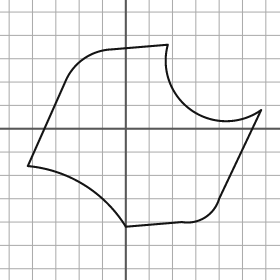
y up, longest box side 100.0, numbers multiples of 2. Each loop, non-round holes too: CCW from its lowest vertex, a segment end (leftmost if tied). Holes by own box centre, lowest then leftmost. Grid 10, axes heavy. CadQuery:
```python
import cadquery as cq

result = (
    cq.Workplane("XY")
    .moveTo(0.0, -42.0)
    .lineTo(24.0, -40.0)
    .threePointArc((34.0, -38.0), (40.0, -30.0))
    .lineTo(58.0, 8.0)
    .threePointArc((28.0, 8.0), (18.0, 36.0))
    .lineTo(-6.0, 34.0)
    .threePointArc((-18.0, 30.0), (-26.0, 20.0))
    .lineTo(-42.0, -16.0)
    .threePointArc((-18.0, -24.0), (0.0, -42.0))
    .close()
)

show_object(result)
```